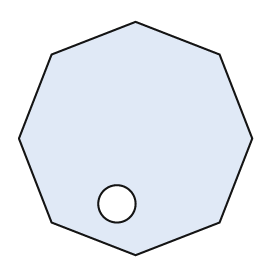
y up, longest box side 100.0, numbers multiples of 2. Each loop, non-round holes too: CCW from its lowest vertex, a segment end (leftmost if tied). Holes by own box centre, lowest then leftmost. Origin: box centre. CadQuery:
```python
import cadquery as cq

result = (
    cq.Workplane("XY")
    .moveTo(0.0, -50.0)
    .lineTo(36.0, -36.0)
    .lineTo(50.0, 0.0)
    .lineTo(36.0, 36.0)
    .lineTo(0.0, 50.0)
    .lineTo(-36.0, 36.0)
    .lineTo(-50.0, 0.0)
    .lineTo(-36.0, -36.0)
    .close()
    .moveTo(-8.0, -28.0)
    .circle(8.0)
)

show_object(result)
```